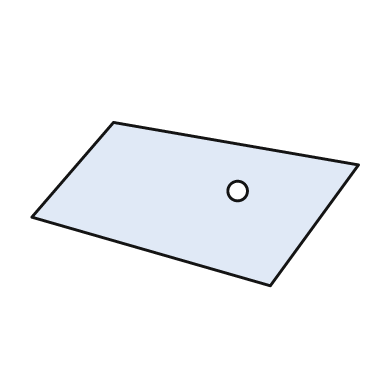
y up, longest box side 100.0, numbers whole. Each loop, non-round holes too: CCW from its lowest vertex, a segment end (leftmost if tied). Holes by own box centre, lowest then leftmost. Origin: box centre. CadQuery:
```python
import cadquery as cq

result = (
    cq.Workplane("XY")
    .moveTo(23.0, -25.0)
    .lineTo(50.0, 12.0)
    .lineTo(-25.0, 25.0)
    .lineTo(-50.0, -4.0)
    .close()
    .moveTo(13.0, 4.0)
    .circle(3.0)
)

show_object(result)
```